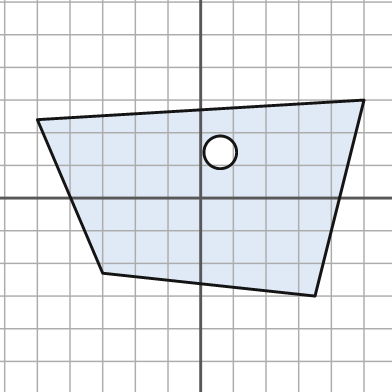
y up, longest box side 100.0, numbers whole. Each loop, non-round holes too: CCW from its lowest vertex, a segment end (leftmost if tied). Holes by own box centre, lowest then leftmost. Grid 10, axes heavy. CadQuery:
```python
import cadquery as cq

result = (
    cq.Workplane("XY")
    .moveTo(35.0, -30.0)
    .lineTo(50.0, 30.0)
    .lineTo(-50.0, 24.0)
    .lineTo(-30.0, -23.0)
    .close()
    .moveTo(6.0, 14.0)
    .circle(5.0)
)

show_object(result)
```